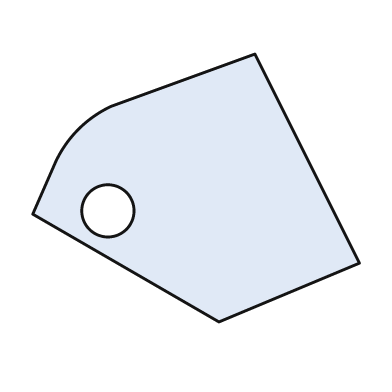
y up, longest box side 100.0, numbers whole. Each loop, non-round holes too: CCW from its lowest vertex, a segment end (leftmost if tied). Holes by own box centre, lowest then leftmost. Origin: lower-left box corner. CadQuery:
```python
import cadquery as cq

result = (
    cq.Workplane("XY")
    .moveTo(57.0, 0.0)
    .lineTo(100.0, 18.0)
    .lineTo(68.0, 82.0)
    .lineTo(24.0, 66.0)
    .threePointArc((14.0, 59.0), (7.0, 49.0))
    .lineTo(0.0, 33.0)
    .close()
    .moveTo(23.0, 34.0)
    .circle(8.0)
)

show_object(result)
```